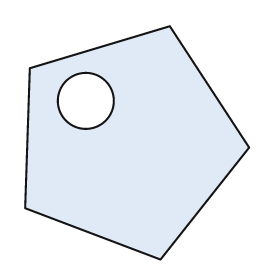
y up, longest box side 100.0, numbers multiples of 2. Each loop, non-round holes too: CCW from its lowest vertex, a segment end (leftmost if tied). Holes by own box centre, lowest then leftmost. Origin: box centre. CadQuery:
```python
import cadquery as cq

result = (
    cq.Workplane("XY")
    .moveTo(10.0, -50.0)
    .lineTo(48.0, -2.0)
    .lineTo(14.0, 50.0)
    .lineTo(-46.0, 32.0)
    .lineTo(-48.0, -28.0)
    .close()
    .moveTo(-22.0, 18.0)
    .circle(12.0)
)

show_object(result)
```